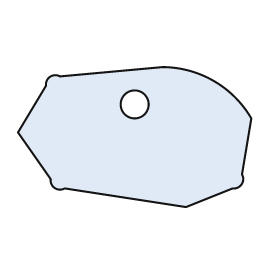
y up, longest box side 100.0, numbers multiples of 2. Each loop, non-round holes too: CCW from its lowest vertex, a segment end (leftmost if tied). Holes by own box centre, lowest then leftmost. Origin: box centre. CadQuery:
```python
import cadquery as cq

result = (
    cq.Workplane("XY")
    .moveTo(22.0, -30.0)
    .lineTo(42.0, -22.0)
    .threePointArc((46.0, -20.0), (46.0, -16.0))
    .lineTo(50.0, 8.0)
    .threePointArc((34.0, 24.0), (12.0, 30.0))
    .lineTo(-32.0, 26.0)
    .threePointArc((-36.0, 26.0), (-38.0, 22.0))
    .lineTo(-50.0, 2.0)
    .lineTo(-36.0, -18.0)
    .threePointArc((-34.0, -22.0), (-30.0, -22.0))
    .close()
    .moveTo(0.0, 14.0)
    .circle(6.0)
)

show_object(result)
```